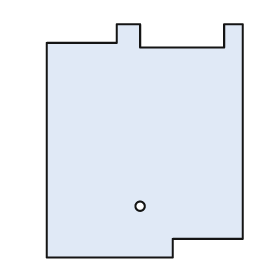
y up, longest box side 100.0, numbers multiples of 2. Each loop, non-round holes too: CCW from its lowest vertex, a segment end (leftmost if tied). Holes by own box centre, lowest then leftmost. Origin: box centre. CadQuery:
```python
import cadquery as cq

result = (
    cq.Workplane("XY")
    .moveTo(-42.0, -50.0)
    .lineTo(12.0, -50.0)
    .lineTo(12.0, -42.0)
    .lineTo(42.0, -42.0)
    .lineTo(42.0, 50.0)
    .lineTo(34.0, 50.0)
    .lineTo(34.0, 40.0)
    .lineTo(-2.0, 40.0)
    .lineTo(-2.0, 50.0)
    .lineTo(-12.0, 50.0)
    .lineTo(-12.0, 42.0)
    .lineTo(-42.0, 42.0)
    .close()
    .moveTo(-2.0, -28.0)
    .circle(2.0)
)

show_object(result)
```